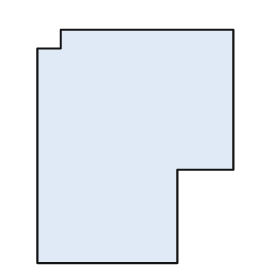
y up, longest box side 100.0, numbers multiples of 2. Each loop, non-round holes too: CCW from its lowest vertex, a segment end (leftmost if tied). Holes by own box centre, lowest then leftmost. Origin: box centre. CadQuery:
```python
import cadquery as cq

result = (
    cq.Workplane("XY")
    .moveTo(-42.0, -50.0)
    .lineTo(18.0, -50.0)
    .lineTo(18.0, -10.0)
    .lineTo(42.0, -10.0)
    .lineTo(42.0, 50.0)
    .lineTo(-32.0, 50.0)
    .lineTo(-32.0, 42.0)
    .lineTo(-42.0, 42.0)
    .close()
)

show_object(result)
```